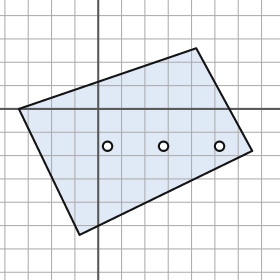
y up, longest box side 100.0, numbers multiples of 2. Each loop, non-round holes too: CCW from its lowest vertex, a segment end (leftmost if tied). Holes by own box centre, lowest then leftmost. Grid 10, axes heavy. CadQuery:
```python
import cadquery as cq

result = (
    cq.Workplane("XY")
    .moveTo(-8.0, -54.0)
    .lineTo(66.0, -18.0)
    .lineTo(42.0, 26.0)
    .lineTo(-34.0, 0.0)
    .close()
    .moveTo(4.0, -16.0)
    .circle(2.0)
    .moveTo(28.0, -16.0)
    .circle(2.0)
    .moveTo(52.0, -16.0)
    .circle(2.0)
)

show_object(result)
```